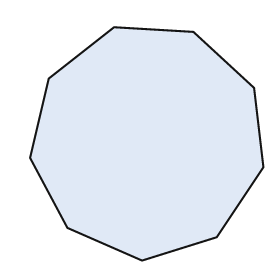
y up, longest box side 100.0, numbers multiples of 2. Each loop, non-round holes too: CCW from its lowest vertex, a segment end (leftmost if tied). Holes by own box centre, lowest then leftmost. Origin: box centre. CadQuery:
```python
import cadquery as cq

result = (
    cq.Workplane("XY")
    .moveTo(-2.0, -50.0)
    .lineTo(30.0, -40.0)
    .lineTo(50.0, -10.0)
    .lineTo(46.0, 24.0)
    .lineTo(20.0, 48.0)
    .lineTo(-14.0, 50.0)
    .lineTo(-42.0, 28.0)
    .lineTo(-50.0, -6.0)
    .lineTo(-34.0, -36.0)
    .close()
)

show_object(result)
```